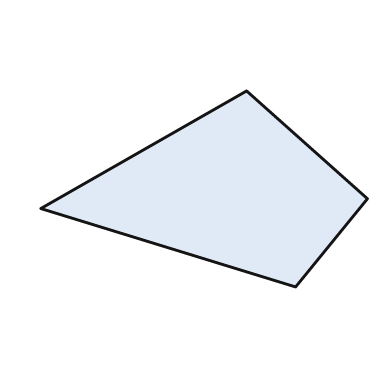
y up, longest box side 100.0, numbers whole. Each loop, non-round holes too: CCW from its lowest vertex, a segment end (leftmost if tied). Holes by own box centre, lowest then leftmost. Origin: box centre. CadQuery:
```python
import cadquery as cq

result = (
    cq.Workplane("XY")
    .moveTo(28.0, -30.0)
    .lineTo(50.0, -3.0)
    .lineTo(13.0, 30.0)
    .lineTo(-50.0, -6.0)
    .close()
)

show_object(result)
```